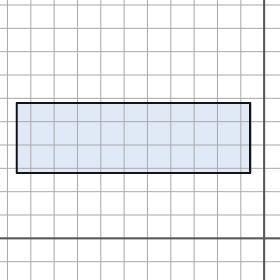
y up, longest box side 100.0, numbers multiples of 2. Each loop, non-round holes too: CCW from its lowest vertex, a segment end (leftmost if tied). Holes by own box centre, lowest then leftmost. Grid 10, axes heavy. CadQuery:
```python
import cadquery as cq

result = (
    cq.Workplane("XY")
    .moveTo(-106.0, 28.0)
    .lineTo(-6.0, 28.0)
    .lineTo(-6.0, 58.0)
    .lineTo(-106.0, 58.0)
    .close()
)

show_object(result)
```